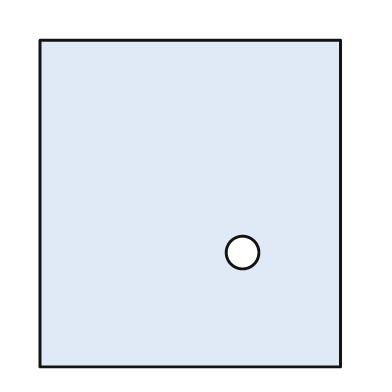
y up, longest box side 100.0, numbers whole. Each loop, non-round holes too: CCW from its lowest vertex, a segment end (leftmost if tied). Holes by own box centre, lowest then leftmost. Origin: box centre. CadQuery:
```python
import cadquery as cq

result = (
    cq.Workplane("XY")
    .moveTo(-46.0, -50.0)
    .lineTo(46.0, -50.0)
    .lineTo(46.0, 50.0)
    .lineTo(-46.0, 50.0)
    .close()
    .moveTo(16.0, -15.0)
    .circle(5.0)
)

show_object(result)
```